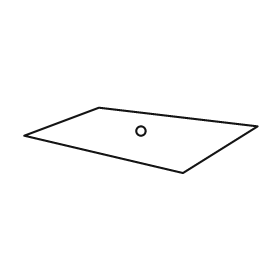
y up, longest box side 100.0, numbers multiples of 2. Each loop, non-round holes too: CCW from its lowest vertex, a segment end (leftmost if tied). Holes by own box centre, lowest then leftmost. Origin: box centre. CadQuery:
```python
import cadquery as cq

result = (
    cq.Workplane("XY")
    .moveTo(18.0, -14.0)
    .lineTo(50.0, 6.0)
    .lineTo(-18.0, 14.0)
    .lineTo(-50.0, 2.0)
    .close()
    .moveTo(0.0, 4.0)
    .circle(2.0)
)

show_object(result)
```